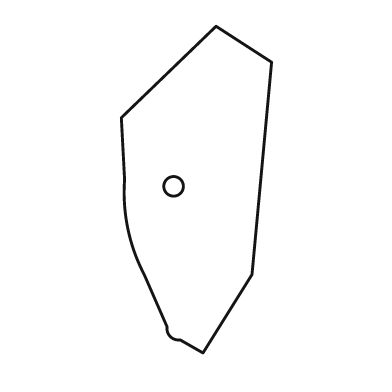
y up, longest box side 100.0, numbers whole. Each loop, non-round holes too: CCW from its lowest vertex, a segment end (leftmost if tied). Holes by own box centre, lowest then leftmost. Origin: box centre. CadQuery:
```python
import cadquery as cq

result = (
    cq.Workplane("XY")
    .moveTo(2.0, -50.0)
    .lineTo(17.0, -26.0)
    .lineTo(23.0, 39.0)
    .lineTo(6.0, 50.0)
    .lineTo(-23.0, 22.0)
    .lineTo(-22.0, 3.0)
    .threePointArc((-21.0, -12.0), (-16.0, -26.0))
    .lineTo(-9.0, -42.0)
    .threePointArc((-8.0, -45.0), (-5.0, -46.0))
    .close()
    .moveTo(-7.0, 1.0)
    .circle(3.0)
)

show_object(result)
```